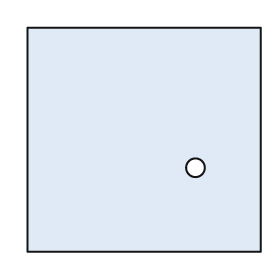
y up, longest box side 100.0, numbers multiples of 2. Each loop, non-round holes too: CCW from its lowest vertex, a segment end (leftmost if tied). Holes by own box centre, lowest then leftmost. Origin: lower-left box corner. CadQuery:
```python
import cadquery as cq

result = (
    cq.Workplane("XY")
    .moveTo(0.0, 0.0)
    .lineTo(100.0, 0.0)
    .lineTo(100.0, 96.0)
    .lineTo(0.0, 96.0)
    .close()
    .moveTo(72.0, 36.0)
    .circle(4.0)
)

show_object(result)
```